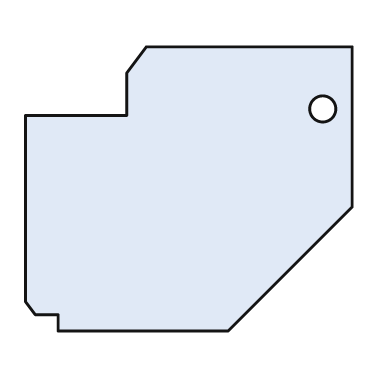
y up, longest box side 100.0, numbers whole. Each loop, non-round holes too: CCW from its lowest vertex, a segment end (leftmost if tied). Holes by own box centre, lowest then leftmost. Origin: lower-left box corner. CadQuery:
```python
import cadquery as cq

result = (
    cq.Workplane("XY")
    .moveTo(10.0, 0.0)
    .lineTo(62.0, 0.0)
    .lineTo(100.0, 38.0)
    .lineTo(100.0, 87.0)
    .lineTo(37.0, 87.0)
    .lineTo(31.0, 79.0)
    .lineTo(31.0, 66.0)
    .lineTo(0.0, 66.0)
    .lineTo(0.0, 9.0)
    .lineTo(3.0, 5.0)
    .lineTo(10.0, 5.0)
    .close()
    .moveTo(91.0, 68.0)
    .circle(4.0)
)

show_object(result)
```